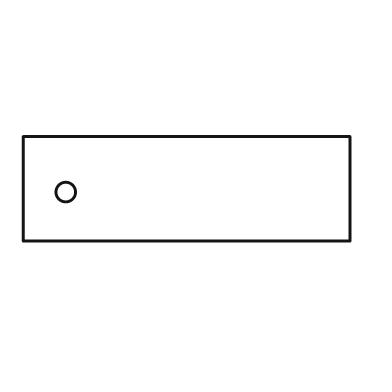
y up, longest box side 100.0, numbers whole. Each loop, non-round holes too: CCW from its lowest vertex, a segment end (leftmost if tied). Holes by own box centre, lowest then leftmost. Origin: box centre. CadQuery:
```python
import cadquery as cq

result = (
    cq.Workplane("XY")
    .moveTo(-50.0, -16.0)
    .lineTo(50.0, -16.0)
    .lineTo(50.0, 16.0)
    .lineTo(-50.0, 16.0)
    .close()
    .moveTo(-37.0, -1.0)
    .circle(3.0)
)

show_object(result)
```